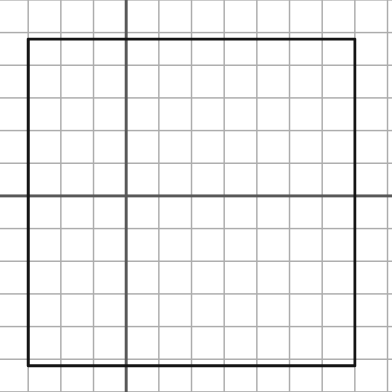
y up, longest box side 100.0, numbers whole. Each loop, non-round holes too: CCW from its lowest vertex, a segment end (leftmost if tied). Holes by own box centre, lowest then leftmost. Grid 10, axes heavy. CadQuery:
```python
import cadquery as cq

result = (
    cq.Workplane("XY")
    .moveTo(-30.0, -52.0)
    .lineTo(70.0, -52.0)
    .lineTo(70.0, 48.0)
    .lineTo(-30.0, 48.0)
    .close()
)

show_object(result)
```